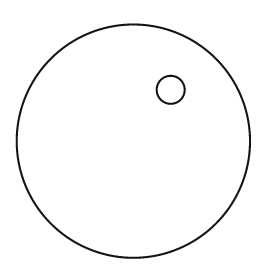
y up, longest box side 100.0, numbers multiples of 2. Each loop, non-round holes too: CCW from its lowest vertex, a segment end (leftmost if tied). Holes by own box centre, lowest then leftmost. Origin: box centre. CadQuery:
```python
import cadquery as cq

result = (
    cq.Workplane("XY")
    .moveTo(0.0, 0.0)
    .circle(50.0)
    .moveTo(16.0, 22.0)
    .circle(6.0)
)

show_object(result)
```